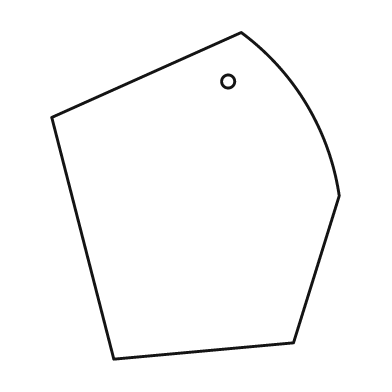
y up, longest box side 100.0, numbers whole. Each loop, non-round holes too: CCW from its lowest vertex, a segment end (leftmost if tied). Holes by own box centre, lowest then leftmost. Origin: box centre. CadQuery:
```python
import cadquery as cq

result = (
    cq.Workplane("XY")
    .moveTo(-25.0, -50.0)
    .lineTo(30.0, -45.0)
    .lineTo(44.0, 0.0)
    .threePointArc((34.0, 28.0), (14.0, 50.0))
    .lineTo(-44.0, 24.0)
    .close()
    .moveTo(10.0, 35.0)
    .circle(2.0)
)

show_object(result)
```